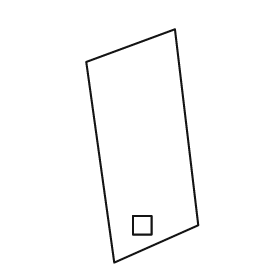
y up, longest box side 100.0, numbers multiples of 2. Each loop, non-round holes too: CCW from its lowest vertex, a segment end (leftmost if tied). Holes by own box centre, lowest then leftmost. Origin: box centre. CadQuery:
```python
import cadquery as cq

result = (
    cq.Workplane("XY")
    .moveTo(-12.0, -50.0)
    .lineTo(24.0, -34.0)
    .lineTo(14.0, 50.0)
    .lineTo(-24.0, 36.0)
    .close()
    .moveTo(-4.0, -38.0)
    .lineTo(4.0, -38.0)
    .lineTo(4.0, -30.0)
    .lineTo(-4.0, -30.0)
    .close()
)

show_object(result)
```